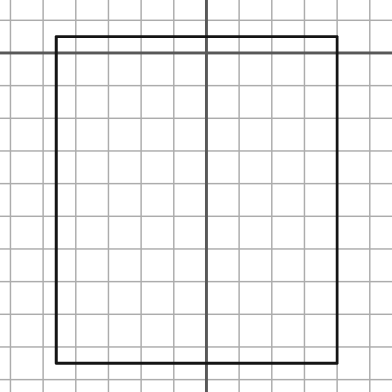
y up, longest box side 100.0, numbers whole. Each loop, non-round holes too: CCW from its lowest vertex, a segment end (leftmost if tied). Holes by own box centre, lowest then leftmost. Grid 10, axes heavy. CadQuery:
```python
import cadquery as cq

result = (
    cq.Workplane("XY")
    .moveTo(-46.0, -95.0)
    .lineTo(40.0, -95.0)
    .lineTo(40.0, 5.0)
    .lineTo(-46.0, 5.0)
    .close()
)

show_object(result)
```